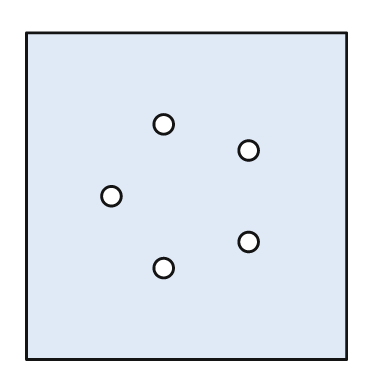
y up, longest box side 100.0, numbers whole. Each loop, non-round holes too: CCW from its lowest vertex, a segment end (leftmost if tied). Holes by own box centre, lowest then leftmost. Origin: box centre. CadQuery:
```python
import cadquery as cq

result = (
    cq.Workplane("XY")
    .moveTo(-49.0, -50.0)
    .lineTo(49.0, -50.0)
    .lineTo(49.0, 50.0)
    .lineTo(-49.0, 50.0)
    .close()
    .moveTo(-7.0, -22.0)
    .circle(3.0)
    .moveTo(19.0, -14.0)
    .circle(3.0)
    .moveTo(-23.0, 0.0)
    .circle(3.0)
    .moveTo(19.0, 14.0)
    .circle(3.0)
    .moveTo(-7.0, 22.0)
    .circle(3.0)
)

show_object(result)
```